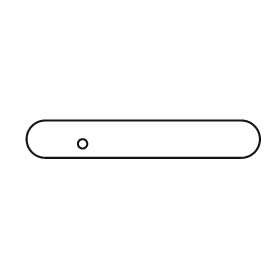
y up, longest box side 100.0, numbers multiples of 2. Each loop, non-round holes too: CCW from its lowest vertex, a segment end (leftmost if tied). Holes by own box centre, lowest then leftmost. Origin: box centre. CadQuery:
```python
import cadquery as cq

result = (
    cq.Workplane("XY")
    .moveTo(-42.0, -8.0)
    .lineTo(42.0, -8.0)
    .threePointArc((50.0, 0.0), (42.0, 8.0))
    .lineTo(-42.0, 8.0)
    .threePointArc((-50.0, 0.0), (-42.0, -8.0))
    .close()
    .moveTo(-26.0, -2.0)
    .circle(2.0)
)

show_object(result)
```